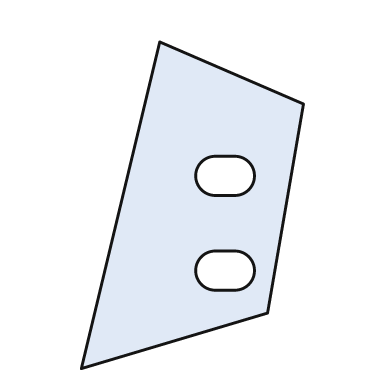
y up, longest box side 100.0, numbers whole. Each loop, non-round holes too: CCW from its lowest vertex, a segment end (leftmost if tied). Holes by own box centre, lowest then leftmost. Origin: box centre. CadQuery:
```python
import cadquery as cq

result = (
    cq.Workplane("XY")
    .moveTo(-34.0, -50.0)
    .lineTo(23.0, -33.0)
    .lineTo(34.0, 31.0)
    .lineTo(-10.0, 50.0)
    .close()
    .moveTo(7.0, -26.0)
    .lineTo(13.0, -26.0)
    .threePointArc((19.0, -20.0), (13.0, -14.0))
    .lineTo(7.0, -14.0)
    .threePointArc((1.0, -20.0), (7.0, -26.0))
    .close()
    .moveTo(7.0, 3.0)
    .lineTo(13.0, 3.0)
    .threePointArc((19.0, 9.0), (13.0, 15.0))
    .lineTo(7.0, 15.0)
    .threePointArc((1.0, 9.0), (7.0, 3.0))
    .close()
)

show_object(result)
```